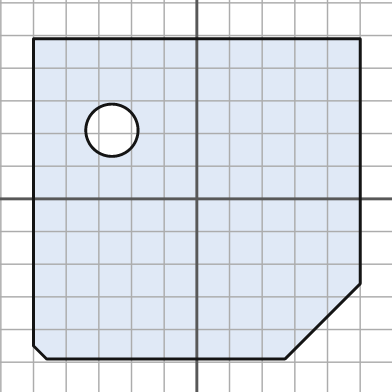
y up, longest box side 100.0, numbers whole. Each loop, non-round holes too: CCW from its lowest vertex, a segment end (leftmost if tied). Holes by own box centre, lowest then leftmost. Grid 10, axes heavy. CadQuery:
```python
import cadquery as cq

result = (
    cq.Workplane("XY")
    .moveTo(-46.0, -49.0)
    .lineTo(27.0, -49.0)
    .lineTo(50.0, -26.0)
    .lineTo(50.0, 49.0)
    .lineTo(-50.0, 49.0)
    .lineTo(-50.0, -45.0)
    .close()
    .moveTo(-26.0, 21.0)
    .circle(8.0)
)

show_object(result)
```